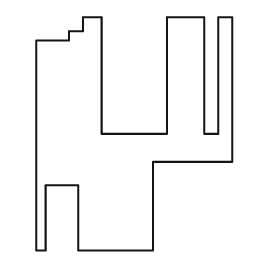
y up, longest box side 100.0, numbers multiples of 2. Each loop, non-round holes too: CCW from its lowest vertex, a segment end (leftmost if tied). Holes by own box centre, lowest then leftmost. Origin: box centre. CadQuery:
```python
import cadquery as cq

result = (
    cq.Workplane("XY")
    .moveTo(-42.0, -50.0)
    .lineTo(-38.0, -50.0)
    .lineTo(-38.0, -22.0)
    .lineTo(-24.0, -22.0)
    .lineTo(-24.0, -50.0)
    .lineTo(8.0, -50.0)
    .lineTo(8.0, -12.0)
    .lineTo(42.0, -12.0)
    .lineTo(42.0, 50.0)
    .lineTo(36.0, 50.0)
    .lineTo(36.0, 0.0)
    .lineTo(30.0, 0.0)
    .lineTo(30.0, 50.0)
    .lineTo(14.0, 50.0)
    .lineTo(14.0, 0.0)
    .lineTo(-14.0, 0.0)
    .lineTo(-14.0, 50.0)
    .lineTo(-22.0, 50.0)
    .lineTo(-22.0, 44.0)
    .lineTo(-28.0, 44.0)
    .lineTo(-28.0, 40.0)
    .lineTo(-42.0, 40.0)
    .close()
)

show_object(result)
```